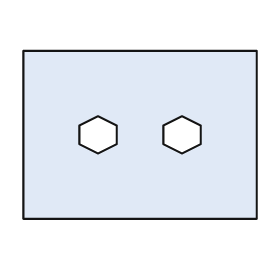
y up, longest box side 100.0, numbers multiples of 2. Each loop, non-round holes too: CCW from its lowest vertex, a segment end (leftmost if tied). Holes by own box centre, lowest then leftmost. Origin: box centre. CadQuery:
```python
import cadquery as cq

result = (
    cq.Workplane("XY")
    .moveTo(-50.0, -36.0)
    .lineTo(50.0, -36.0)
    .lineTo(50.0, 36.0)
    .lineTo(-50.0, 36.0)
    .close()
    .moveTo(-18.0, -8.0)
    .lineTo(-10.0, -4.0)
    .lineTo(-10.0, 4.0)
    .lineTo(-18.0, 8.0)
    .lineTo(-26.0, 4.0)
    .lineTo(-26.0, -4.0)
    .close()
    .moveTo(18.0, -8.0)
    .lineTo(26.0, -4.0)
    .lineTo(26.0, 4.0)
    .lineTo(18.0, 8.0)
    .lineTo(10.0, 4.0)
    .lineTo(10.0, -4.0)
    .close()
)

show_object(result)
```